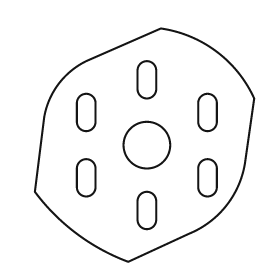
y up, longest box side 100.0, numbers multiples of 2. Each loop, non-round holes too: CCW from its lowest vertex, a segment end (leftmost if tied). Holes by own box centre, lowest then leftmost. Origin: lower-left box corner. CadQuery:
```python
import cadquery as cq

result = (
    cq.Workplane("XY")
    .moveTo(40.0, 0.0)
    .lineTo(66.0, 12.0)
    .threePointArc((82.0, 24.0), (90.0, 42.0))
    .lineTo(94.0, 70.0)
    .threePointArc((78.0, 90.0), (54.0, 100.0))
    .lineTo(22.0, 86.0)
    .threePointArc((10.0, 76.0), (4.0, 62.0))
    .lineTo(0.0, 30.0)
    .threePointArc((18.0, 12.0), (40.0, 0.0))
    .close()
    .moveTo(44.0, 18.0)
    .threePointArc((48.0, 14.0), (52.0, 18.0))
    .lineTo(52.0, 26.0)
    .threePointArc((48.0, 30.0), (44.0, 26.0))
    .close()
    .moveTo(18.0, 32.0)
    .threePointArc((22.0, 28.0), (26.0, 32.0))
    .lineTo(26.0, 40.0)
    .threePointArc((22.0, 44.0), (18.0, 40.0))
    .close()
    .moveTo(70.0, 32.0)
    .threePointArc((74.0, 28.0), (78.0, 32.0))
    .lineTo(78.0, 40.0)
    .threePointArc((74.0, 44.0), (70.0, 40.0))
    .close()
    .moveTo(48.0, 50.0)
    .circle(10.0)
    .moveTo(18.0, 60.0)
    .threePointArc((22.0, 56.0), (26.0, 60.0))
    .lineTo(26.0, 68.0)
    .threePointArc((22.0, 72.0), (18.0, 68.0))
    .close()
    .moveTo(70.0, 60.0)
    .threePointArc((74.0, 56.0), (78.0, 60.0))
    .lineTo(78.0, 68.0)
    .threePointArc((74.0, 72.0), (70.0, 68.0))
    .close()
    .moveTo(44.0, 74.0)
    .threePointArc((48.0, 70.0), (52.0, 74.0))
    .lineTo(52.0, 82.0)
    .threePointArc((48.0, 86.0), (44.0, 82.0))
    .close()
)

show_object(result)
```